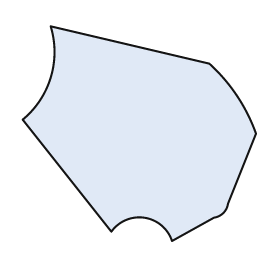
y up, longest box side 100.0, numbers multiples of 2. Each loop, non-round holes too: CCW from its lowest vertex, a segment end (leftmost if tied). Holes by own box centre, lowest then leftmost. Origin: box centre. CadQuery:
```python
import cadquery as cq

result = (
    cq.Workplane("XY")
    .moveTo(14.0, -46.0)
    .lineTo(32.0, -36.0)
    .threePointArc((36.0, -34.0), (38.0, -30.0))
    .lineTo(50.0, 0.0)
    .threePointArc((42.0, 16.0), (30.0, 30.0))
    .lineTo(-38.0, 46.0)
    .threePointArc((-38.0, 24.0), (-50.0, 6.0))
    .lineTo(-12.0, -42.0)
    .threePointArc((2.0, -36.0), (14.0, -46.0))
    .close()
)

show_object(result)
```